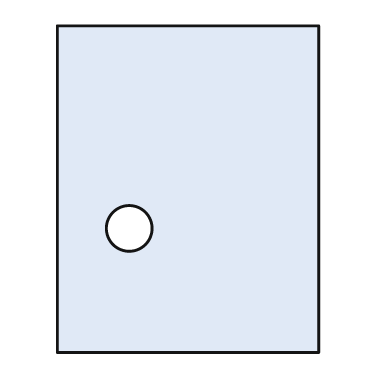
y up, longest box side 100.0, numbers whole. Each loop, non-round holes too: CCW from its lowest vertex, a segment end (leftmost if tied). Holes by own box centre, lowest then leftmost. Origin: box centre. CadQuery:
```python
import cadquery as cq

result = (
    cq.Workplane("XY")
    .moveTo(-40.0, -50.0)
    .lineTo(40.0, -50.0)
    .lineTo(40.0, 50.0)
    .lineTo(-40.0, 50.0)
    .close()
    .moveTo(-18.0, -12.0)
    .circle(7.0)
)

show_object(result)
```